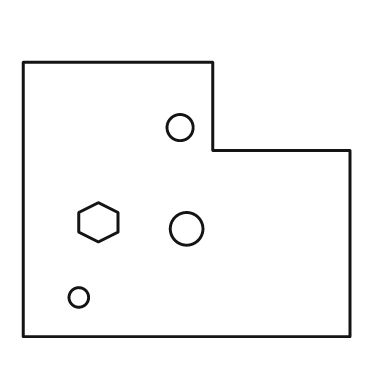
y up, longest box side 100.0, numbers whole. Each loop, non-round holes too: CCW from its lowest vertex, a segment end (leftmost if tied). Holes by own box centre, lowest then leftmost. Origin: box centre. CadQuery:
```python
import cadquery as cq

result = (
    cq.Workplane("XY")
    .moveTo(-50.0, -42.0)
    .lineTo(50.0, -42.0)
    .lineTo(50.0, 15.0)
    .lineTo(8.0, 15.0)
    .lineTo(8.0, 42.0)
    .lineTo(-50.0, 42.0)
    .close()
    .moveTo(-33.0, -30.0)
    .circle(3.0)
    .moveTo(0.0, -9.0)
    .circle(5.0)
    .moveTo(-27.0, -13.0)
    .lineTo(-21.0, -10.0)
    .lineTo(-21.0, -4.0)
    .lineTo(-27.0, -1.0)
    .lineTo(-33.0, -4.0)
    .lineTo(-33.0, -10.0)
    .close()
    .moveTo(-2.0, 22.0)
    .circle(4.0)
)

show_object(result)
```